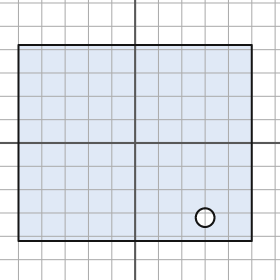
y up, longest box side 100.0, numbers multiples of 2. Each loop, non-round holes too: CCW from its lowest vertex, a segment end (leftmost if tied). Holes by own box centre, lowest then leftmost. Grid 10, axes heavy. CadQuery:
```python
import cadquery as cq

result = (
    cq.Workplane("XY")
    .moveTo(-50.0, -42.0)
    .lineTo(50.0, -42.0)
    .lineTo(50.0, 42.0)
    .lineTo(-50.0, 42.0)
    .close()
    .moveTo(30.0, -32.0)
    .circle(4.0)
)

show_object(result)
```